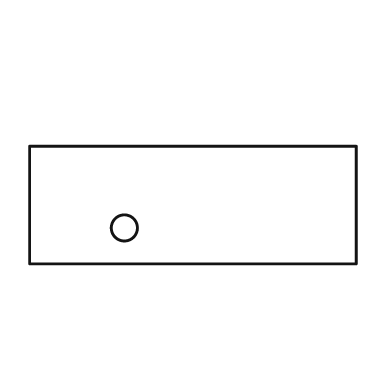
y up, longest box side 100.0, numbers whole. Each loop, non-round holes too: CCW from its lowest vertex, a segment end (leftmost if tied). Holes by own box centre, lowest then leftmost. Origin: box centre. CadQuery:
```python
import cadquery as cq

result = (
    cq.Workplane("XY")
    .moveTo(-50.0, -18.0)
    .lineTo(50.0, -18.0)
    .lineTo(50.0, 18.0)
    .lineTo(-50.0, 18.0)
    .close()
    .moveTo(-21.0, -7.0)
    .circle(4.0)
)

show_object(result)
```